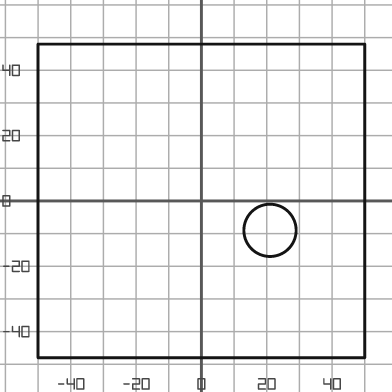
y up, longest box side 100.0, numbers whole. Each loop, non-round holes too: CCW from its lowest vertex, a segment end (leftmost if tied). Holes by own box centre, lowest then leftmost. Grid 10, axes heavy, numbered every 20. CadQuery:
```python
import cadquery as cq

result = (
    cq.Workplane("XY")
    .moveTo(-50.0, -48.0)
    .lineTo(50.0, -48.0)
    .lineTo(50.0, 48.0)
    .lineTo(-50.0, 48.0)
    .close()
    .moveTo(21.0, -9.0)
    .circle(8.0)
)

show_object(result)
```